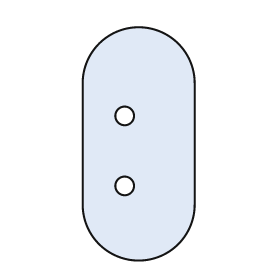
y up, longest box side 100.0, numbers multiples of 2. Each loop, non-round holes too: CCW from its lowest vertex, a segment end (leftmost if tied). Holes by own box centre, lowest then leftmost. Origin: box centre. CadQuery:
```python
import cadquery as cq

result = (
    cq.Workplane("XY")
    .moveTo(-24.0, -26.0)
    .threePointArc((0.0, -50.0), (24.0, -26.0))
    .lineTo(24.0, 26.0)
    .threePointArc((0.0, 50.0), (-24.0, 26.0))
    .close()
    .moveTo(-6.0, -18.0)
    .circle(4.0)
    .moveTo(-6.0, 12.0)
    .circle(4.0)
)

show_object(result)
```